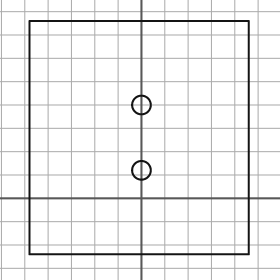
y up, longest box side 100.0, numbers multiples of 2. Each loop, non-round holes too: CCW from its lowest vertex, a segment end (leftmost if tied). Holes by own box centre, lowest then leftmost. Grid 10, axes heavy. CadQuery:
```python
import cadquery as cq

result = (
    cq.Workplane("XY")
    .moveTo(-48.0, -24.0)
    .lineTo(46.0, -24.0)
    .lineTo(46.0, 76.0)
    .lineTo(-48.0, 76.0)
    .close()
    .moveTo(0.0, 12.0)
    .circle(4.0)
    .moveTo(0.0, 40.0)
    .circle(4.0)
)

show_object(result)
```